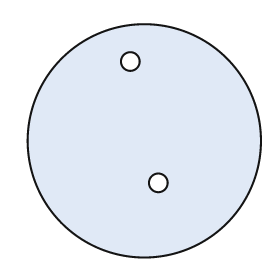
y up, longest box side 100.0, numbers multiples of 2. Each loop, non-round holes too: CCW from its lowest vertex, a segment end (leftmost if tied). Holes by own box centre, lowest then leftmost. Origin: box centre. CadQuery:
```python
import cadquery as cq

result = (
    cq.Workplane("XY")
    .moveTo(0.0, 0.0)
    .circle(50.0)
    .moveTo(6.0, -18.0)
    .circle(4.0)
    .moveTo(-6.0, 34.0)
    .circle(4.0)
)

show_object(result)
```